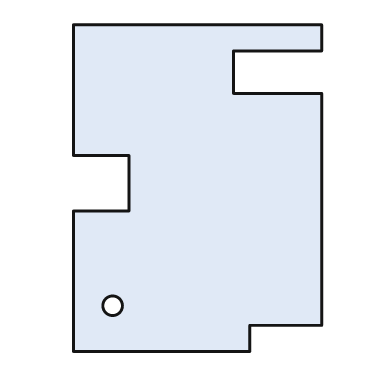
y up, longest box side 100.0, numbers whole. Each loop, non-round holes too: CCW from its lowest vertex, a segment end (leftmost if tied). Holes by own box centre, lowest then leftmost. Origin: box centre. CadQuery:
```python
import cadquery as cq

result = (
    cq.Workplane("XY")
    .moveTo(-38.0, -50.0)
    .lineTo(16.0, -50.0)
    .lineTo(16.0, -42.0)
    .lineTo(38.0, -42.0)
    .lineTo(38.0, 29.0)
    .lineTo(11.0, 29.0)
    .lineTo(11.0, 42.0)
    .lineTo(38.0, 42.0)
    .lineTo(38.0, 50.0)
    .lineTo(-38.0, 50.0)
    .lineTo(-38.0, 10.0)
    .lineTo(-21.0, 10.0)
    .lineTo(-21.0, -7.0)
    .lineTo(-38.0, -7.0)
    .close()
    .moveTo(-26.0, -36.0)
    .circle(3.0)
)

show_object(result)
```